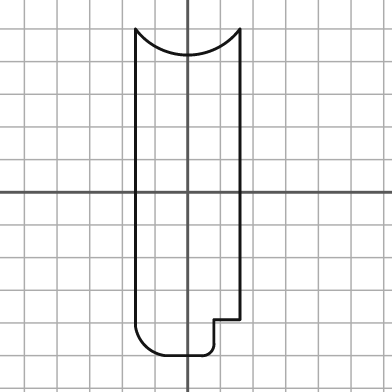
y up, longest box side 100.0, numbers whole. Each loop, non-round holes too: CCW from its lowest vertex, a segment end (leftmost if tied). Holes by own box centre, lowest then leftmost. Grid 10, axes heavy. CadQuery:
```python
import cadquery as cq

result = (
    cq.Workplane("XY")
    .moveTo(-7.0, -50.0)
    .lineTo(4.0, -50.0)
    .threePointArc((7.0, -49.0), (8.0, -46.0))
    .lineTo(8.0, -39.0)
    .lineTo(16.0, -39.0)
    .lineTo(16.0, 50.0)
    .threePointArc((0.0, 42.0), (-16.0, 50.0))
    .lineTo(-16.0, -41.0)
    .threePointArc((-13.0, -47.0), (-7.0, -50.0))
    .close()
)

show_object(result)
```